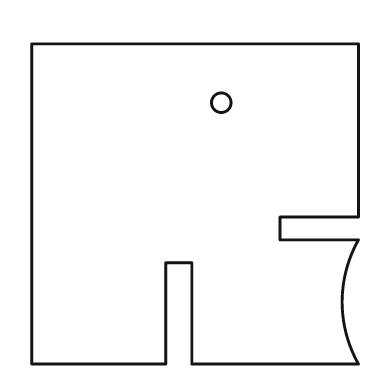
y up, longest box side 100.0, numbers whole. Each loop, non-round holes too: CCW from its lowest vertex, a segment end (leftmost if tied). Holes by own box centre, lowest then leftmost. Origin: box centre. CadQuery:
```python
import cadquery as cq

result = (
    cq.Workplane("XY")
    .moveTo(-50.0, -49.0)
    .lineTo(-9.0, -49.0)
    .lineTo(-9.0, -18.0)
    .lineTo(-1.0, -18.0)
    .lineTo(-1.0, -49.0)
    .lineTo(50.0, -49.0)
    .threePointArc((45.0, -30.0), (50.0, -11.0))
    .lineTo(26.0, -11.0)
    .lineTo(26.0, -4.0)
    .lineTo(50.0, -4.0)
    .lineTo(50.0, 49.0)
    .lineTo(-50.0, 49.0)
    .close()
    .moveTo(8.0, 31.0)
    .circle(3.0)
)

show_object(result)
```